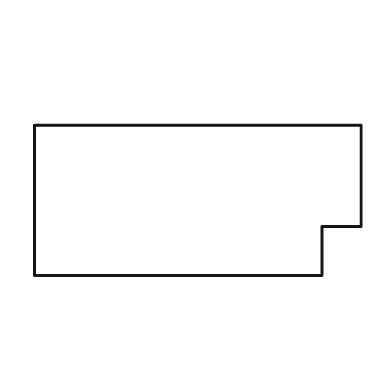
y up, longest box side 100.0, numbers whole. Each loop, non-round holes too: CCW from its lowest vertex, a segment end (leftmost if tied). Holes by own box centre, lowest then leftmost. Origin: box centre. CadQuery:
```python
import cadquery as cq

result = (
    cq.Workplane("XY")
    .moveTo(-50.0, -23.0)
    .lineTo(38.0, -23.0)
    .lineTo(38.0, -8.0)
    .lineTo(50.0, -8.0)
    .lineTo(50.0, 23.0)
    .lineTo(-50.0, 23.0)
    .close()
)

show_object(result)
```